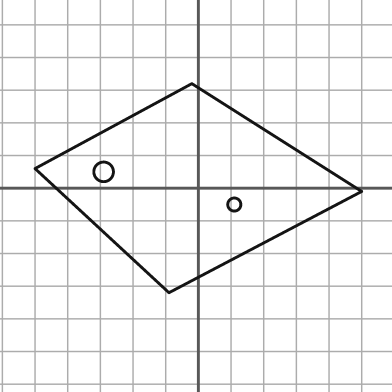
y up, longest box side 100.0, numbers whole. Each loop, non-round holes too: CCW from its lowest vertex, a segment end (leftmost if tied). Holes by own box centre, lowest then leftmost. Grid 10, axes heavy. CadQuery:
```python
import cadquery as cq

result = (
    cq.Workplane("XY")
    .moveTo(-9.0, -32.0)
    .lineTo(50.0, -1.0)
    .lineTo(-2.0, 32.0)
    .lineTo(-50.0, 6.0)
    .close()
    .moveTo(11.0, -5.0)
    .circle(2.0)
    .moveTo(-29.0, 5.0)
    .circle(3.0)
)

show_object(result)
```